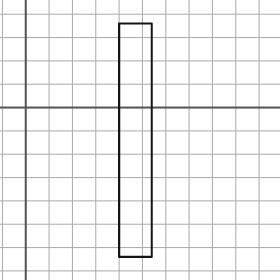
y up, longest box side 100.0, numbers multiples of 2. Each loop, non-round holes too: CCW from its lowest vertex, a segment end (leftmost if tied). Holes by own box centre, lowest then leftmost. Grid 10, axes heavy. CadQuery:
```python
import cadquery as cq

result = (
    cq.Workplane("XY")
    .moveTo(40.0, -64.0)
    .lineTo(54.0, -64.0)
    .lineTo(54.0, 36.0)
    .lineTo(40.0, 36.0)
    .close()
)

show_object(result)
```